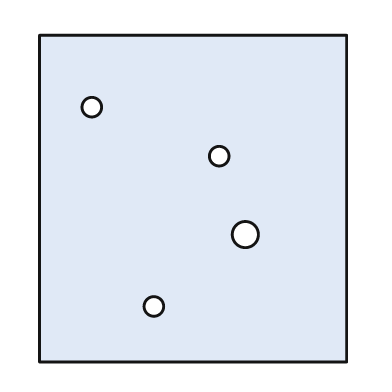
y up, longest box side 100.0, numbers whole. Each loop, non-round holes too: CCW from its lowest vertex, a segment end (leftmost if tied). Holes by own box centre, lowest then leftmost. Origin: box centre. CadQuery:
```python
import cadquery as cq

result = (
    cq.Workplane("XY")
    .moveTo(-47.0, -50.0)
    .lineTo(47.0, -50.0)
    .lineTo(47.0, 50.0)
    .lineTo(-47.0, 50.0)
    .close()
    .moveTo(-12.0, -33.0)
    .circle(3.0)
    .moveTo(16.0, -11.0)
    .circle(4.0)
    .moveTo(8.0, 13.0)
    .circle(3.0)
    .moveTo(-31.0, 28.0)
    .circle(3.0)
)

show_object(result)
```